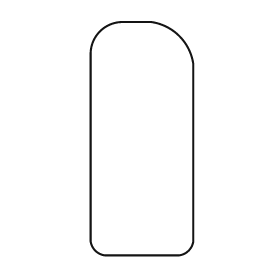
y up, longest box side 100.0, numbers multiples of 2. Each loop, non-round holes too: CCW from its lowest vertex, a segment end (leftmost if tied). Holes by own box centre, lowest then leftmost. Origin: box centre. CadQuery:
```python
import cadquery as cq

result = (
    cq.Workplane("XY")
    .moveTo(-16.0, -50.0)
    .lineTo(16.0, -50.0)
    .threePointArc((20.0, -48.0), (22.0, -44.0))
    .lineTo(22.0, 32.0)
    .threePointArc((16.0, 44.0), (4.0, 50.0))
    .lineTo(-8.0, 50.0)
    .threePointArc((-18.0, 46.0), (-22.0, 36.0))
    .lineTo(-22.0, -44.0)
    .threePointArc((-20.0, -48.0), (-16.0, -50.0))
    .close()
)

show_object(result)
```